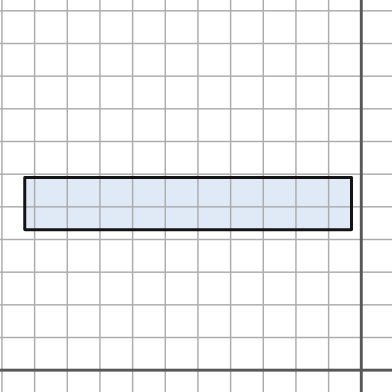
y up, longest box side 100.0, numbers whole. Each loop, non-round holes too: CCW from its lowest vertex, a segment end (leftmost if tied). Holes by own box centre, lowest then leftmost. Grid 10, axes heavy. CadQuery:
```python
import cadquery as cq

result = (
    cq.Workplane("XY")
    .moveTo(-103.0, 43.0)
    .lineTo(-3.0, 43.0)
    .lineTo(-3.0, 59.0)
    .lineTo(-103.0, 59.0)
    .close()
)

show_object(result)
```